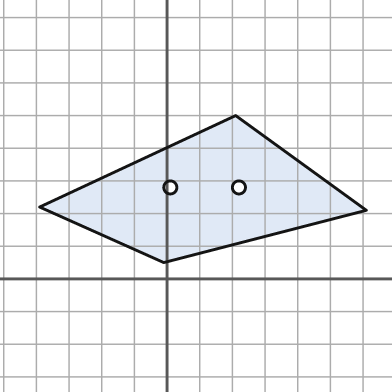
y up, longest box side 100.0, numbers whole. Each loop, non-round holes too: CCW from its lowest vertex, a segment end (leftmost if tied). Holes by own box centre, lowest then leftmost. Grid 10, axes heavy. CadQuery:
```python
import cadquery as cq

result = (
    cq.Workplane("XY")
    .moveTo(-1.0, 5.0)
    .lineTo(61.0, 21.0)
    .lineTo(21.0, 50.0)
    .lineTo(-39.0, 22.0)
    .close()
    .moveTo(1.0, 28.0)
    .circle(2.0)
    .moveTo(22.0, 28.0)
    .circle(2.0)
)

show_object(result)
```